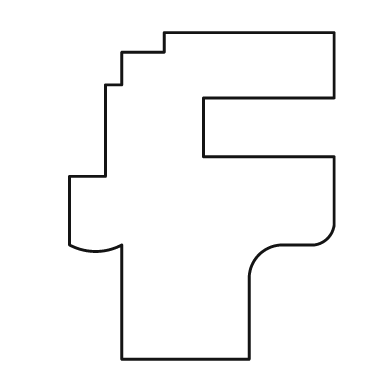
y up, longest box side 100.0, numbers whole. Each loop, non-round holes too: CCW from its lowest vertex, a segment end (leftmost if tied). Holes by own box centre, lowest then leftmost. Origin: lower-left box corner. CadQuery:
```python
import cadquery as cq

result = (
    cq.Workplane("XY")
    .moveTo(16.0, 0.0)
    .lineTo(55.0, 0.0)
    .lineTo(55.0, 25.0)
    .threePointArc((58.0, 32.0), (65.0, 35.0))
    .lineTo(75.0, 35.0)
    .threePointArc((79.0, 37.0), (81.0, 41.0))
    .lineTo(81.0, 62.0)
    .lineTo(41.0, 62.0)
    .lineTo(41.0, 80.0)
    .lineTo(81.0, 80.0)
    .lineTo(81.0, 100.0)
    .lineTo(29.0, 100.0)
    .lineTo(29.0, 94.0)
    .lineTo(16.0, 94.0)
    .lineTo(16.0, 84.0)
    .lineTo(11.0, 84.0)
    .lineTo(11.0, 56.0)
    .lineTo(0.0, 56.0)
    .lineTo(0.0, 35.0)
    .threePointArc((8.0, 33.0), (16.0, 35.0))
    .close()
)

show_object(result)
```